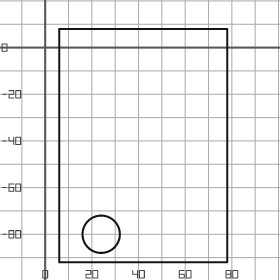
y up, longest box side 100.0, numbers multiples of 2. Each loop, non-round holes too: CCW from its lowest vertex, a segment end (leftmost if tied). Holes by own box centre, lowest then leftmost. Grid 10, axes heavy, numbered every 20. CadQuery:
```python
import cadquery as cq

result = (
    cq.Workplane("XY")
    .moveTo(6.0, -92.0)
    .lineTo(78.0, -92.0)
    .lineTo(78.0, 8.0)
    .lineTo(6.0, 8.0)
    .close()
    .moveTo(24.0, -80.0)
    .circle(8.0)
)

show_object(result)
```